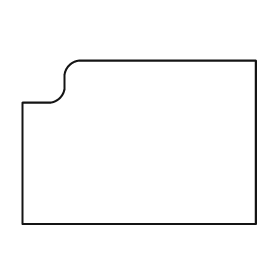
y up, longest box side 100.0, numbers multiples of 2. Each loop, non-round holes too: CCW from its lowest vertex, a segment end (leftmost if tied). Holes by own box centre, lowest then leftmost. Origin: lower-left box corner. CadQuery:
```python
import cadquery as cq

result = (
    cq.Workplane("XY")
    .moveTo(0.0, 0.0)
    .lineTo(100.0, 0.0)
    .lineTo(100.0, 70.0)
    .lineTo(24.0, 70.0)
    .threePointArc((20.0, 68.0), (18.0, 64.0))
    .lineTo(18.0, 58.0)
    .threePointArc((16.0, 54.0), (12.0, 52.0))
    .lineTo(0.0, 52.0)
    .close()
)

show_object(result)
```